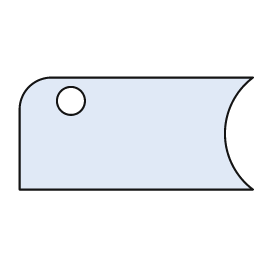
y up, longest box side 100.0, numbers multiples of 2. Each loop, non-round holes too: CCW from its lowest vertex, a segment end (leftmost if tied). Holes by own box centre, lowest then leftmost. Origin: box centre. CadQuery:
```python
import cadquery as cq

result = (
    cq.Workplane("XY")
    .moveTo(-50.0, -24.0)
    .lineTo(50.0, -24.0)
    .threePointArc((38.0, 0.0), (50.0, 24.0))
    .lineTo(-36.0, 24.0)
    .threePointArc((-46.0, 20.0), (-50.0, 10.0))
    .close()
    .moveTo(-28.0, 14.0)
    .circle(6.0)
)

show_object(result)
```